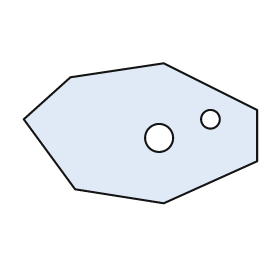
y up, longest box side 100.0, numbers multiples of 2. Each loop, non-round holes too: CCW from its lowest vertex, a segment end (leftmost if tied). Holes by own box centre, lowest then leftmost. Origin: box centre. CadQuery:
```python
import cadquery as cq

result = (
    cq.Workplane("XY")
    .moveTo(10.0, -30.0)
    .lineTo(50.0, -12.0)
    .lineTo(50.0, 10.0)
    .lineTo(10.0, 30.0)
    .lineTo(-30.0, 24.0)
    .lineTo(-50.0, 6.0)
    .lineTo(-28.0, -24.0)
    .close()
    .moveTo(8.0, -2.0)
    .circle(6.0)
    .moveTo(30.0, 6.0)
    .circle(4.0)
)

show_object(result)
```